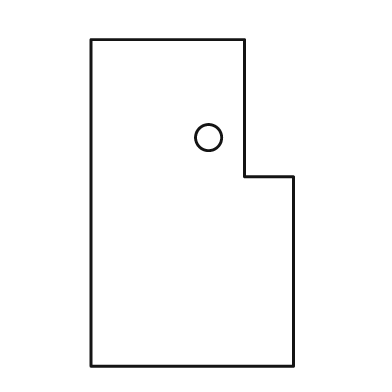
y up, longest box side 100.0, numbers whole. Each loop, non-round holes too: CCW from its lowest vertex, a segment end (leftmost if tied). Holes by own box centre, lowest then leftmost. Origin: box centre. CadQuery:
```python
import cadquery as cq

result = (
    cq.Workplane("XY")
    .moveTo(-31.0, -50.0)
    .lineTo(31.0, -50.0)
    .lineTo(31.0, 8.0)
    .lineTo(16.0, 8.0)
    .lineTo(16.0, 50.0)
    .lineTo(-31.0, 50.0)
    .close()
    .moveTo(5.0, 20.0)
    .circle(4.0)
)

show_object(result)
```